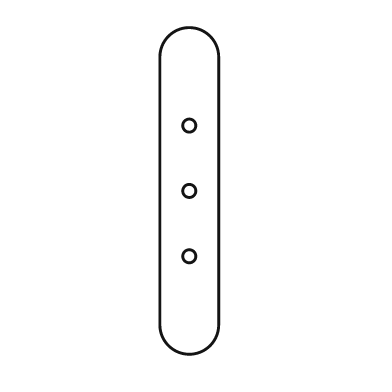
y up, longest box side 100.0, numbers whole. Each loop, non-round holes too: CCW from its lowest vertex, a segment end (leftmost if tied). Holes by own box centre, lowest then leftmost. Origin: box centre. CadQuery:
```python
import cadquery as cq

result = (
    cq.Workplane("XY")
    .moveTo(-9.0, -41.0)
    .threePointArc((0.0, -50.0), (9.0, -41.0))
    .lineTo(9.0, 41.0)
    .threePointArc((0.0, 50.0), (-9.0, 41.0))
    .close()
    .moveTo(0.0, -20.0)
    .circle(2.0)
    .moveTo(0.0, 0.0)
    .circle(2.0)
    .moveTo(0.0, 20.0)
    .circle(2.0)
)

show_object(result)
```